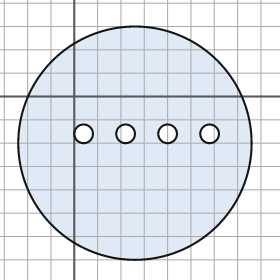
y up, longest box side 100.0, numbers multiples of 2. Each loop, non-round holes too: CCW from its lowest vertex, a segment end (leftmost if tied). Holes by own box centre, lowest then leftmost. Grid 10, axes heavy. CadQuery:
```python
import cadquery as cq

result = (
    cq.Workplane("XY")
    .moveTo(26.0, -20.0)
    .circle(50.0)
    .moveTo(4.0, -16.0)
    .circle(4.0)
    .moveTo(22.0, -16.0)
    .circle(4.0)
    .moveTo(40.0, -16.0)
    .circle(4.0)
    .moveTo(58.0, -16.0)
    .circle(4.0)
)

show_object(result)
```